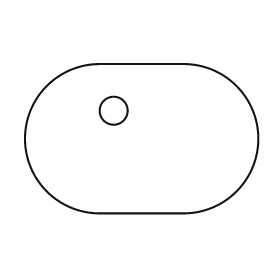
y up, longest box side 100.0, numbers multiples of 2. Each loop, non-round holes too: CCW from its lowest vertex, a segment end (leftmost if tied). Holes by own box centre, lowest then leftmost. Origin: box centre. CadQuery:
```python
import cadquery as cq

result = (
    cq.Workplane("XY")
    .moveTo(-18.0, -32.0)
    .lineTo(18.0, -32.0)
    .threePointArc((50.0, 0.0), (18.0, 32.0))
    .lineTo(-18.0, 32.0)
    .threePointArc((-50.0, 0.0), (-18.0, -32.0))
    .close()
    .moveTo(-12.0, 12.0)
    .circle(6.0)
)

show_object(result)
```